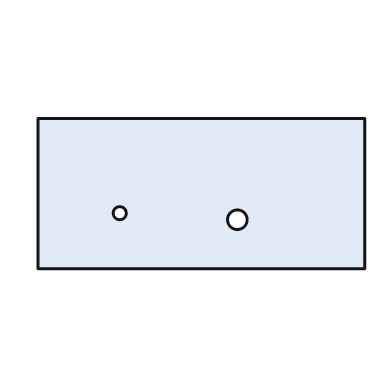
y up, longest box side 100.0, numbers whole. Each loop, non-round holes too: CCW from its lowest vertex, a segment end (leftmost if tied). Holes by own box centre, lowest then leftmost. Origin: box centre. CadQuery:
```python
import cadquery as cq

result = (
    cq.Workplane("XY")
    .moveTo(-50.0, -23.0)
    .lineTo(50.0, -23.0)
    .lineTo(50.0, 23.0)
    .lineTo(-50.0, 23.0)
    .close()
    .moveTo(11.0, -8.0)
    .circle(3.0)
    .moveTo(-25.0, -6.0)
    .circle(2.0)
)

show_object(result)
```